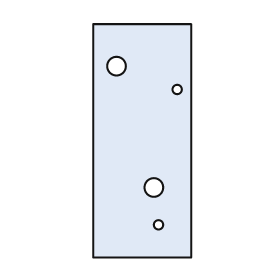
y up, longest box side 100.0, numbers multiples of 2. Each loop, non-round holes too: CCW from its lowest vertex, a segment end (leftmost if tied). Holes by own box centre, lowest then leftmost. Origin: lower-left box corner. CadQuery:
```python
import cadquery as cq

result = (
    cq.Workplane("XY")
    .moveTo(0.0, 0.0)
    .lineTo(42.0, 0.0)
    .lineTo(42.0, 100.0)
    .lineTo(0.0, 100.0)
    .close()
    .moveTo(28.0, 14.0)
    .circle(2.0)
    .moveTo(26.0, 30.0)
    .circle(4.0)
    .moveTo(36.0, 72.0)
    .circle(2.0)
    .moveTo(10.0, 82.0)
    .circle(4.0)
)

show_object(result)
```